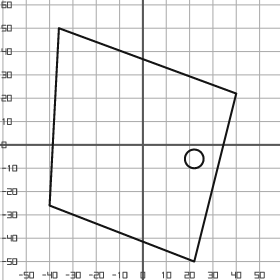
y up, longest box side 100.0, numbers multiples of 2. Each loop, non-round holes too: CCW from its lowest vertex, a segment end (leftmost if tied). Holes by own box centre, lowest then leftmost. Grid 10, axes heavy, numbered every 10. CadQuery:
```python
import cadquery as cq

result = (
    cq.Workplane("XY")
    .moveTo(22.0, -50.0)
    .lineTo(40.0, 22.0)
    .lineTo(-36.0, 50.0)
    .lineTo(-40.0, -26.0)
    .close()
    .moveTo(22.0, -6.0)
    .circle(4.0)
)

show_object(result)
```